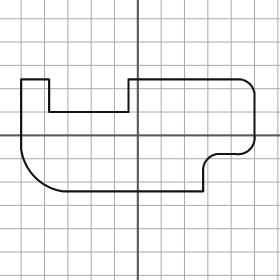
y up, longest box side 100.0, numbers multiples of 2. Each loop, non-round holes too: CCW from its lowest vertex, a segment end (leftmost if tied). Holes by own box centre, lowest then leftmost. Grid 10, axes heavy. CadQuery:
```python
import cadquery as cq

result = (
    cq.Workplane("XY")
    .moveTo(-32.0, -24.0)
    .lineTo(28.0, -24.0)
    .lineTo(28.0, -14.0)
    .threePointArc((30.0, -10.0), (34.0, -8.0))
    .lineTo(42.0, -8.0)
    .threePointArc((48.0, -6.0), (50.0, 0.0))
    .lineTo(50.0, 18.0)
    .threePointArc((48.0, 22.0), (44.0, 24.0))
    .lineTo(-4.0, 24.0)
    .lineTo(-4.0, 10.0)
    .lineTo(-38.0, 10.0)
    .lineTo(-38.0, 24.0)
    .lineTo(-50.0, 24.0)
    .lineTo(-50.0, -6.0)
    .threePointArc((-44.0, -18.0), (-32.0, -24.0))
    .close()
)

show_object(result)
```